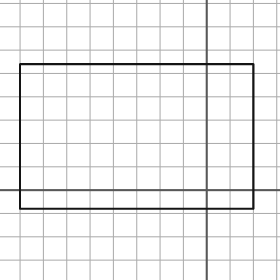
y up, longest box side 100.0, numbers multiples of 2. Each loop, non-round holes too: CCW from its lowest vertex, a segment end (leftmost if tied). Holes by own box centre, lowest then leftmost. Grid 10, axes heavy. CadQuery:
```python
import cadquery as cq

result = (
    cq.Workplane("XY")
    .moveTo(-80.0, -8.0)
    .lineTo(20.0, -8.0)
    .lineTo(20.0, 54.0)
    .lineTo(-80.0, 54.0)
    .close()
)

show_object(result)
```